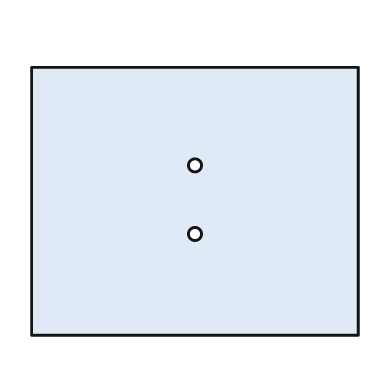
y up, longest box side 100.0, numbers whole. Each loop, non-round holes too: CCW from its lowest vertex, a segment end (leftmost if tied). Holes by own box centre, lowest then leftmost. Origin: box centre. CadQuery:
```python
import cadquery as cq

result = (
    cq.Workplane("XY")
    .moveTo(-50.0, -41.0)
    .lineTo(50.0, -41.0)
    .lineTo(50.0, 41.0)
    .lineTo(-50.0, 41.0)
    .close()
    .moveTo(0.0, -10.0)
    .circle(2.0)
    .moveTo(0.0, 11.0)
    .circle(2.0)
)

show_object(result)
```